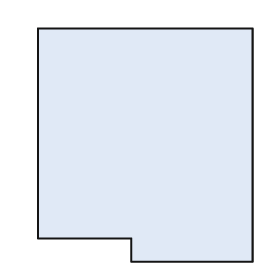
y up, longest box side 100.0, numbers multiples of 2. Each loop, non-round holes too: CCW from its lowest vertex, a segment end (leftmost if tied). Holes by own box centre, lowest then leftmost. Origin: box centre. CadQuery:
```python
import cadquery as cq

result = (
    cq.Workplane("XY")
    .moveTo(-6.0, -50.0)
    .lineTo(46.0, -50.0)
    .lineTo(46.0, 50.0)
    .lineTo(-46.0, 50.0)
    .lineTo(-46.0, -40.0)
    .lineTo(-6.0, -40.0)
    .close()
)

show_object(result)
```